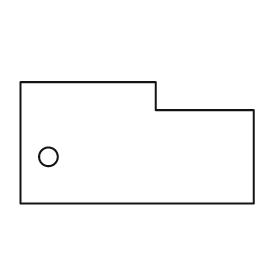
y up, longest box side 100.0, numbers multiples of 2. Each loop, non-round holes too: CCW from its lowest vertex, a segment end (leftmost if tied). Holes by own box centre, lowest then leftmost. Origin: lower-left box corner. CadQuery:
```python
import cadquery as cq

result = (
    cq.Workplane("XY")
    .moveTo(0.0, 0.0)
    .lineTo(100.0, 0.0)
    .lineTo(100.0, 40.0)
    .lineTo(58.0, 40.0)
    .lineTo(58.0, 52.0)
    .lineTo(0.0, 52.0)
    .close()
    .moveTo(12.0, 20.0)
    .circle(4.0)
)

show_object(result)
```